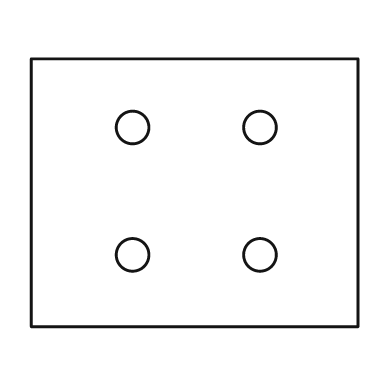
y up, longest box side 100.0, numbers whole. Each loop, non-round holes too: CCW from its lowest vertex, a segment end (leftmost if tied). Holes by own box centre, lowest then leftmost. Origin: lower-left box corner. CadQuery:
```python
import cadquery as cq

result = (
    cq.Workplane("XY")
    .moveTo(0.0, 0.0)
    .lineTo(100.0, 0.0)
    .lineTo(100.0, 82.0)
    .lineTo(0.0, 82.0)
    .close()
    .moveTo(31.0, 22.0)
    .circle(5.0)
    .moveTo(70.0, 22.0)
    .circle(5.0)
    .moveTo(31.0, 61.0)
    .circle(5.0)
    .moveTo(70.0, 61.0)
    .circle(5.0)
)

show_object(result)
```